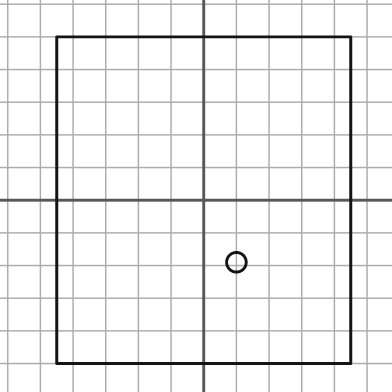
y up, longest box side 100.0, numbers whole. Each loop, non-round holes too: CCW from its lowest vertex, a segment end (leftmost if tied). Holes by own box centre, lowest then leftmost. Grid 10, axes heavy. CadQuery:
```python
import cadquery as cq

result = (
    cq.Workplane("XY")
    .moveTo(-45.0, -50.0)
    .lineTo(45.0, -50.0)
    .lineTo(45.0, 50.0)
    .lineTo(-45.0, 50.0)
    .close()
    .moveTo(10.0, -19.0)
    .circle(3.0)
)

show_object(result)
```